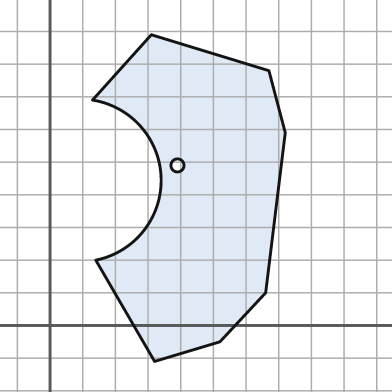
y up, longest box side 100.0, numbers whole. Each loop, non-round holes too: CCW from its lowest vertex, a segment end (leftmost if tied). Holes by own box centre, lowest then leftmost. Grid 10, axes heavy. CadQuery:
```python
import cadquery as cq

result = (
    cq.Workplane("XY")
    .moveTo(32.0, -11.0)
    .lineTo(52.0, -5.0)
    .lineTo(66.0, 10.0)
    .lineTo(72.0, 59.0)
    .lineTo(67.0, 78.0)
    .lineTo(31.0, 89.0)
    .lineTo(13.0, 69.0)
    .threePointArc((34.0, 45.0), (14.0, 20.0))
    .close()
    .moveTo(39.0, 49.0)
    .circle(2.0)
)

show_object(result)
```